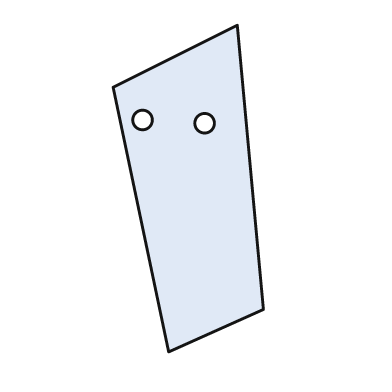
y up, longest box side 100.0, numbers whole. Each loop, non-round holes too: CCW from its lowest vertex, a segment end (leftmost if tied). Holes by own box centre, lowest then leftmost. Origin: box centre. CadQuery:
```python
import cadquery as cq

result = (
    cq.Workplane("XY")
    .moveTo(-6.0, -50.0)
    .lineTo(23.0, -37.0)
    .lineTo(15.0, 50.0)
    .lineTo(-23.0, 31.0)
    .close()
    .moveTo(5.0, 20.0)
    .circle(3.0)
    .moveTo(-14.0, 21.0)
    .circle(3.0)
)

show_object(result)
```